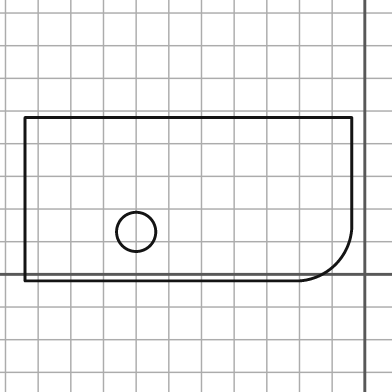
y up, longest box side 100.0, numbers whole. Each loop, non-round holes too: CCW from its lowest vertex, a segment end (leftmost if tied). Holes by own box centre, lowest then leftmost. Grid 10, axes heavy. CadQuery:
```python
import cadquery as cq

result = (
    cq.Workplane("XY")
    .moveTo(-104.0, -2.0)
    .lineTo(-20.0, -2.0)
    .threePointArc((-9.0, 3.0), (-4.0, 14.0))
    .lineTo(-4.0, 48.0)
    .lineTo(-104.0, 48.0)
    .close()
    .moveTo(-70.0, 13.0)
    .circle(6.0)
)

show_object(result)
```